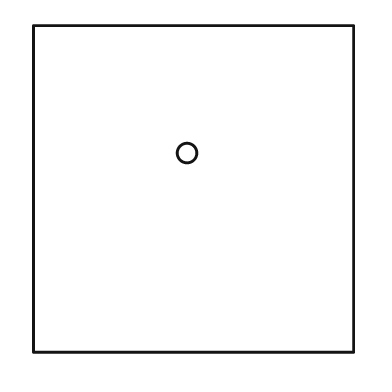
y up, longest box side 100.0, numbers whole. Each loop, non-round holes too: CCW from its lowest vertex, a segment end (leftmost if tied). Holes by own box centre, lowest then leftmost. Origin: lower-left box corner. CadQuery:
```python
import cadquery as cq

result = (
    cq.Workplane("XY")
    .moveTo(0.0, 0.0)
    .lineTo(98.0, 0.0)
    .lineTo(98.0, 100.0)
    .lineTo(0.0, 100.0)
    .close()
    .moveTo(47.0, 61.0)
    .circle(3.0)
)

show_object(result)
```